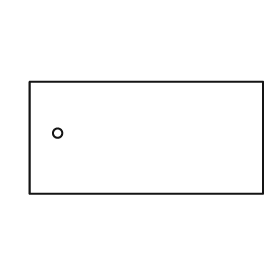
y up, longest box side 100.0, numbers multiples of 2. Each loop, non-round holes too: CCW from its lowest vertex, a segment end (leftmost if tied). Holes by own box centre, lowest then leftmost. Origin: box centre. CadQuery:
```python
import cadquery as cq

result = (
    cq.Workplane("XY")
    .moveTo(-50.0, -24.0)
    .lineTo(50.0, -24.0)
    .lineTo(50.0, 24.0)
    .lineTo(-50.0, 24.0)
    .close()
    .moveTo(-38.0, 2.0)
    .circle(2.0)
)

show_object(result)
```